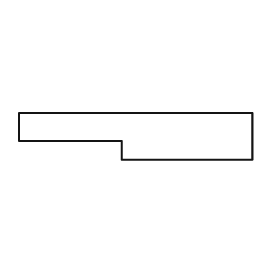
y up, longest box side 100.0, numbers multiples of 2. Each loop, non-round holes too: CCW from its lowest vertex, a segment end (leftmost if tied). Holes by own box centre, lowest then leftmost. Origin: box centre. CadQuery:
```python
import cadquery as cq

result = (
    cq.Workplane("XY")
    .moveTo(-6.0, -10.0)
    .lineTo(50.0, -10.0)
    .lineTo(50.0, 10.0)
    .lineTo(-50.0, 10.0)
    .lineTo(-50.0, -2.0)
    .lineTo(-6.0, -2.0)
    .close()
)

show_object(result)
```